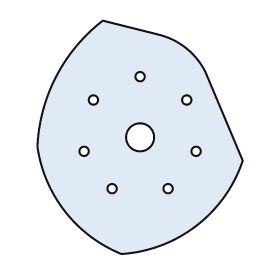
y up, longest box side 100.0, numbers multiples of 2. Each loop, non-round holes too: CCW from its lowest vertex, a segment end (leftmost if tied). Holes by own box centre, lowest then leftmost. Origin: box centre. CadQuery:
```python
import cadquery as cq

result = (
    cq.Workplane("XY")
    .moveTo(-8.0, -50.0)
    .threePointArc((24.0, -38.0), (44.0, -10.0))
    .lineTo(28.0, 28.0)
    .threePointArc((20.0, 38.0), (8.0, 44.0))
    .lineTo(-16.0, 50.0)
    .threePointArc((-36.0, 26.0), (-44.0, -4.0))
    .threePointArc((-32.0, -32.0), (-8.0, -50.0))
    .close()
    .moveTo(-12.0, -22.0)
    .circle(2.0)
    .moveTo(12.0, -22.0)
    .circle(2.0)
    .moveTo(-24.0, -6.0)
    .circle(2.0)
    .moveTo(24.0, -6.0)
    .circle(2.0)
    .moveTo(0.0, 0.0)
    .circle(6.0)
    .moveTo(-20.0, 16.0)
    .circle(2.0)
    .moveTo(20.0, 16.0)
    .circle(2.0)
    .moveTo(0.0, 26.0)
    .circle(2.0)
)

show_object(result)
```